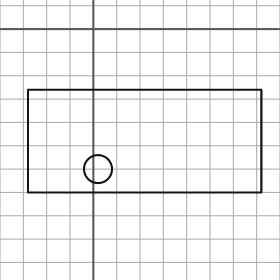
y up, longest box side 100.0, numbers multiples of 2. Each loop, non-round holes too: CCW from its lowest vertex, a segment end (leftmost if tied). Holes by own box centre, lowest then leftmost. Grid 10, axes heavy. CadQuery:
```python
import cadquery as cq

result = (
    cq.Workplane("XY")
    .moveTo(-28.0, -70.0)
    .lineTo(72.0, -70.0)
    .lineTo(72.0, -26.0)
    .lineTo(-28.0, -26.0)
    .close()
    .moveTo(2.0, -60.0)
    .circle(6.0)
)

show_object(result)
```